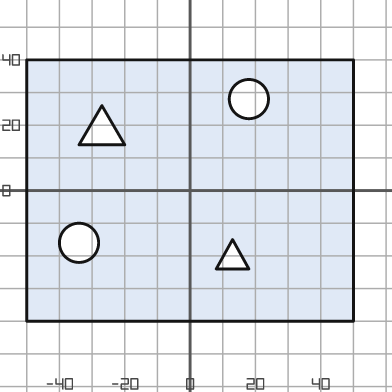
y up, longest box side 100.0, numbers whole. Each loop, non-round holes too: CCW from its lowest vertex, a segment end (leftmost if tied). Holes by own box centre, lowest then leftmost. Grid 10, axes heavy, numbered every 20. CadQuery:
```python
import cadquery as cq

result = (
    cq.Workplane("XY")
    .moveTo(-50.0, -40.0)
    .lineTo(50.0, -40.0)
    .lineTo(50.0, 40.0)
    .lineTo(-50.0, 40.0)
    .close()
    .moveTo(8.0, -24.0)
    .lineTo(18.0, -24.0)
    .lineTo(13.0, -15.0)
    .close()
    .moveTo(-34.0, -16.0)
    .circle(6.0)
    .moveTo(-34.0, 14.0)
    .lineTo(-20.0, 14.0)
    .lineTo(-27.0, 26.0)
    .close()
    .moveTo(18.0, 28.0)
    .circle(6.0)
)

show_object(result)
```